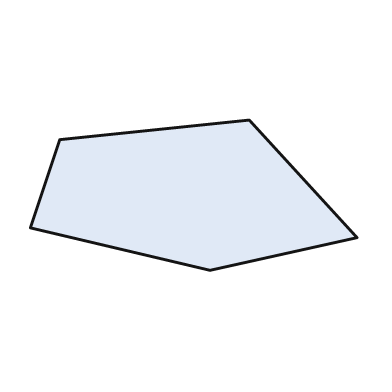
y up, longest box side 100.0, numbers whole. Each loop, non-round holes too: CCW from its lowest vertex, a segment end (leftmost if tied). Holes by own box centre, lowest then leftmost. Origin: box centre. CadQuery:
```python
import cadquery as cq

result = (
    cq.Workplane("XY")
    .moveTo(5.0, -23.0)
    .lineTo(50.0, -13.0)
    .lineTo(17.0, 23.0)
    .lineTo(-41.0, 17.0)
    .lineTo(-50.0, -10.0)
    .close()
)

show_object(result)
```